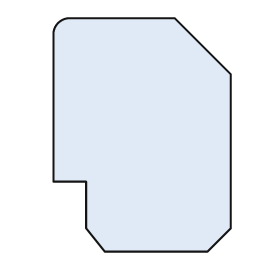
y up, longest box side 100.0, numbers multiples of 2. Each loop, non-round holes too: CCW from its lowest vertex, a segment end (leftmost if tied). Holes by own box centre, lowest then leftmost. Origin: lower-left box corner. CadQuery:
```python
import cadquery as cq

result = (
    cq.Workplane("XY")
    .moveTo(22.0, 0.0)
    .lineTo(66.0, 0.0)
    .lineTo(76.0, 10.0)
    .lineTo(76.0, 76.0)
    .lineTo(52.0, 100.0)
    .lineTo(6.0, 100.0)
    .threePointArc((2.0, 98.0), (0.0, 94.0))
    .lineTo(0.0, 30.0)
    .lineTo(14.0, 30.0)
    .lineTo(14.0, 10.0)
    .close()
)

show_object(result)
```